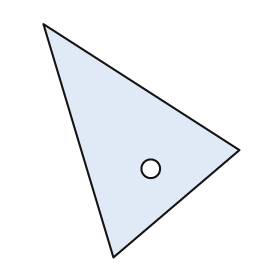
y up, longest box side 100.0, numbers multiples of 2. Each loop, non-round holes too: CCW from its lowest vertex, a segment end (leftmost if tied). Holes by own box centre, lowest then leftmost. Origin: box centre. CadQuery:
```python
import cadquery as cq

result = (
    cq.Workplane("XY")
    .moveTo(-12.0, -50.0)
    .lineTo(42.0, -4.0)
    .lineTo(-42.0, 50.0)
    .close()
    .moveTo(4.0, -12.0)
    .circle(4.0)
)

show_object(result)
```